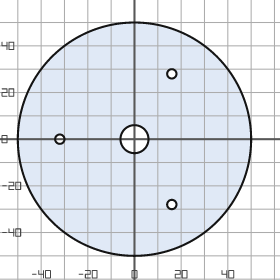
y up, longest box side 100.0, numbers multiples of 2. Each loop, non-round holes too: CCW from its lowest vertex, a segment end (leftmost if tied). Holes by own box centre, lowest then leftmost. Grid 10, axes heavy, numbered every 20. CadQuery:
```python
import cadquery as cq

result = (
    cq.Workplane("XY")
    .moveTo(0.0, 0.0)
    .circle(50.0)
    .moveTo(16.0, -28.0)
    .circle(2.0)
    .moveTo(-32.0, 0.0)
    .circle(2.0)
    .moveTo(0.0, 0.0)
    .circle(6.0)
    .moveTo(16.0, 28.0)
    .circle(2.0)
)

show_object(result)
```